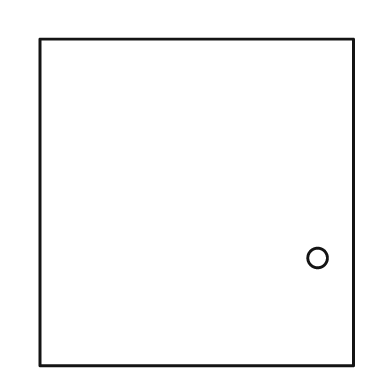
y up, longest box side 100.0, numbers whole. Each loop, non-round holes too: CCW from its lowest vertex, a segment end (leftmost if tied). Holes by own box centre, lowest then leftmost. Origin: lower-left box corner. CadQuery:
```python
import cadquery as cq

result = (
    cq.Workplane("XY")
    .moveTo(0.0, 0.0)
    .lineTo(96.0, 0.0)
    .lineTo(96.0, 100.0)
    .lineTo(0.0, 100.0)
    .close()
    .moveTo(85.0, 33.0)
    .circle(3.0)
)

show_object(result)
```